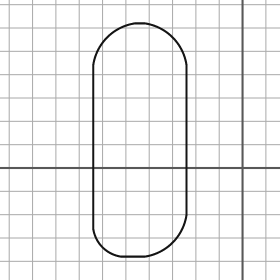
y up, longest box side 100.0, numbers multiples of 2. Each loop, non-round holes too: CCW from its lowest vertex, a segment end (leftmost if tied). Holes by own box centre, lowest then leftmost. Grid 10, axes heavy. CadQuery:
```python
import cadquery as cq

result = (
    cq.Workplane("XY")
    .moveTo(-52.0, -38.0)
    .lineTo(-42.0, -38.0)
    .threePointArc((-30.0, -32.0), (-24.0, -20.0))
    .lineTo(-24.0, 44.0)
    .threePointArc((-30.0, 56.0), (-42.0, 62.0))
    .lineTo(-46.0, 62.0)
    .threePointArc((-58.0, 56.0), (-64.0, 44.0))
    .lineTo(-64.0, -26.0)
    .threePointArc((-60.0, -34.0), (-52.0, -38.0))
    .close()
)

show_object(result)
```